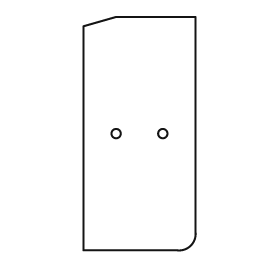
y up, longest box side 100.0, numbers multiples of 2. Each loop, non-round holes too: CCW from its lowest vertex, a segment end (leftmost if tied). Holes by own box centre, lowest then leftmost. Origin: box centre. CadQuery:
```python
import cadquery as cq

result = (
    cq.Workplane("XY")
    .moveTo(-24.0, -50.0)
    .lineTo(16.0, -50.0)
    .threePointArc((22.0, -48.0), (24.0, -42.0))
    .lineTo(24.0, 50.0)
    .lineTo(-10.0, 50.0)
    .lineTo(-24.0, 46.0)
    .close()
    .moveTo(-10.0, 0.0)
    .circle(2.0)
    .moveTo(10.0, 0.0)
    .circle(2.0)
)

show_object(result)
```